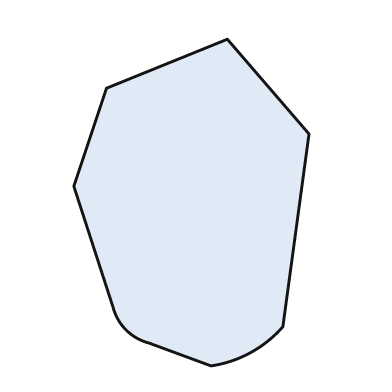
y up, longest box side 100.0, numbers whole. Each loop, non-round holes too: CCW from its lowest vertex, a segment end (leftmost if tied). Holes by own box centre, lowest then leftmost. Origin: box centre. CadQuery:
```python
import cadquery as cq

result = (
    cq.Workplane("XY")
    .moveTo(6.0, -50.0)
    .threePointArc((18.0, -46.0), (28.0, -38.0))
    .lineTo(36.0, 21.0)
    .lineTo(11.0, 50.0)
    .lineTo(-26.0, 35.0)
    .lineTo(-36.0, 5.0)
    .lineTo(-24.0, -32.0)
    .threePointArc((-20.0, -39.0), (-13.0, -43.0))
    .close()
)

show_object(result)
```